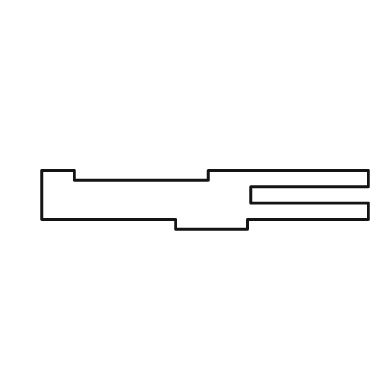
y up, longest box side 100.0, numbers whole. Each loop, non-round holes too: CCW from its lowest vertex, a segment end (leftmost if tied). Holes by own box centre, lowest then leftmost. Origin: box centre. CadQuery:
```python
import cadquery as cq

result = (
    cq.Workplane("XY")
    .moveTo(-9.0, -9.0)
    .lineTo(13.0, -9.0)
    .lineTo(13.0, -6.0)
    .lineTo(50.0, -6.0)
    .lineTo(50.0, -1.0)
    .lineTo(14.0, -1.0)
    .lineTo(14.0, 4.0)
    .lineTo(50.0, 4.0)
    .lineTo(50.0, 9.0)
    .lineTo(1.0, 9.0)
    .lineTo(1.0, 6.0)
    .lineTo(-40.0, 6.0)
    .lineTo(-40.0, 9.0)
    .lineTo(-50.0, 9.0)
    .lineTo(-50.0, -6.0)
    .lineTo(-9.0, -6.0)
    .close()
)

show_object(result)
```